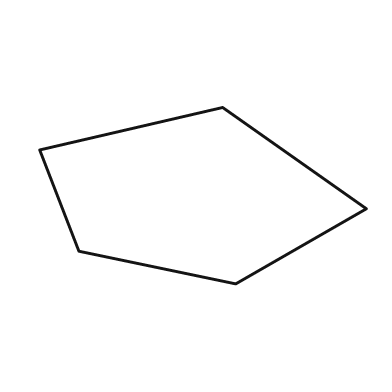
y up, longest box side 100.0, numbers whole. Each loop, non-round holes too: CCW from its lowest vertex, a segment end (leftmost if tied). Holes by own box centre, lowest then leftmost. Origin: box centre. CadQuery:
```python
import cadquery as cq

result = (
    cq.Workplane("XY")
    .moveTo(10.0, -27.0)
    .lineTo(50.0, -4.0)
    .lineTo(6.0, 27.0)
    .lineTo(-50.0, 14.0)
    .lineTo(-38.0, -17.0)
    .close()
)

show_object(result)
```